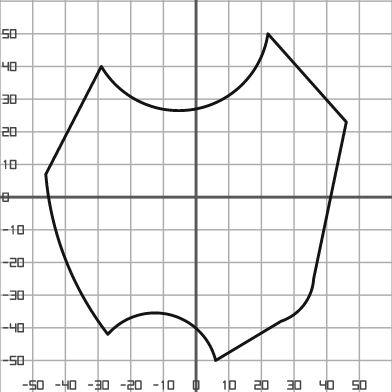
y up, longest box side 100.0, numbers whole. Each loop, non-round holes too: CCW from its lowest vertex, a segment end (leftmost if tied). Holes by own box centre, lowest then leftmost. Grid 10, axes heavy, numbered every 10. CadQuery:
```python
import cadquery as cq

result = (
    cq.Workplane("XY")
    .moveTo(6.0, -50.0)
    .lineTo(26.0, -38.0)
    .threePointArc((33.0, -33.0), (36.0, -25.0))
    .lineTo(46.0, 23.0)
    .lineTo(22.0, 50.0)
    .threePointArc((0.0, 27.0), (-29.0, 40.0))
    .lineTo(-46.0, 7.0)
    .threePointArc((-40.0, -19.0), (-27.0, -42.0))
    .threePointArc((-8.0, -36.0), (6.0, -50.0))
    .close()
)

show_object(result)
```